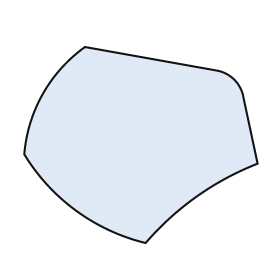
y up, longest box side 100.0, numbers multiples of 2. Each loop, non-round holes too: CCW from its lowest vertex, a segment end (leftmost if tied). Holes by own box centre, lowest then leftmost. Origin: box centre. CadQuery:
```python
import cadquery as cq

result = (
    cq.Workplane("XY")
    .moveTo(2.0, -42.0)
    .threePointArc((24.0, -22.0), (50.0, -8.0))
    .lineTo(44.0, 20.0)
    .threePointArc((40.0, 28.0), (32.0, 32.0))
    .lineTo(-24.0, 42.0)
    .threePointArc((-42.0, 22.0), (-50.0, -4.0))
    .threePointArc((-28.0, -28.0), (2.0, -42.0))
    .close()
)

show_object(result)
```